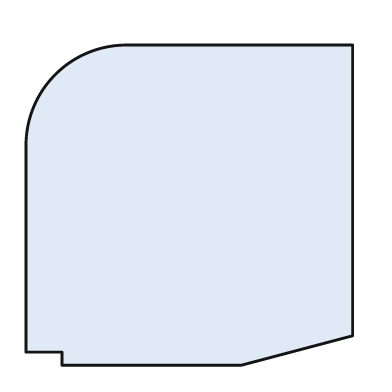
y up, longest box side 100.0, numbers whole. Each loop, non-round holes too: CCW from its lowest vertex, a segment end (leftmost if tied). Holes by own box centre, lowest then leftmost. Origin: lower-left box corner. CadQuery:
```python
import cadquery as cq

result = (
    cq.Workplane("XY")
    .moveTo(11.0, 0.0)
    .lineTo(66.0, 0.0)
    .lineTo(100.0, 9.0)
    .lineTo(100.0, 98.0)
    .lineTo(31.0, 98.0)
    .threePointArc((9.0, 89.0), (0.0, 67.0))
    .lineTo(0.0, 4.0)
    .lineTo(11.0, 4.0)
    .close()
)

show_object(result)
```